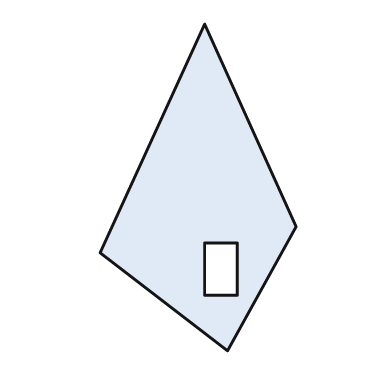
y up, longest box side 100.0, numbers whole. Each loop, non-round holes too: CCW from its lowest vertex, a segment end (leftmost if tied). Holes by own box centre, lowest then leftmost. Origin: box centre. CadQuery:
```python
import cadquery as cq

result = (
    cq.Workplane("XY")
    .moveTo(9.0, -50.0)
    .lineTo(30.0, -12.0)
    .lineTo(2.0, 50.0)
    .lineTo(-30.0, -20.0)
    .close()
    .moveTo(2.0, -33.0)
    .lineTo(12.0, -33.0)
    .lineTo(12.0, -17.0)
    .lineTo(2.0, -17.0)
    .close()
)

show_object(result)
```